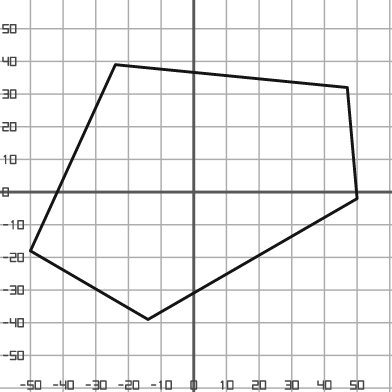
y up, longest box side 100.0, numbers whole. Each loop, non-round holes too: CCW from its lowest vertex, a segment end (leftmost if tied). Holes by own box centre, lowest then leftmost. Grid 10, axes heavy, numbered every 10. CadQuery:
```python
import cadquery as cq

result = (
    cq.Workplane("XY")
    .moveTo(-14.0, -39.0)
    .lineTo(50.0, -2.0)
    .lineTo(47.0, 32.0)
    .lineTo(-24.0, 39.0)
    .lineTo(-50.0, -18.0)
    .close()
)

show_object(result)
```